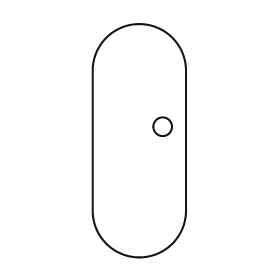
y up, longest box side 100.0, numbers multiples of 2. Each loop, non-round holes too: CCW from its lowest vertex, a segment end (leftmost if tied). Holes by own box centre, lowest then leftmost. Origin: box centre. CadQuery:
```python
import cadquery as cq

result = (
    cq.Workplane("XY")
    .moveTo(-20.0, -30.0)
    .threePointArc((0.0, -50.0), (20.0, -30.0))
    .lineTo(20.0, 30.0)
    .threePointArc((0.0, 50.0), (-20.0, 30.0))
    .close()
    .moveTo(10.0, 6.0)
    .circle(4.0)
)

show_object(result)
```